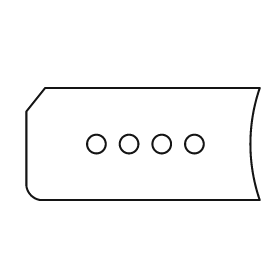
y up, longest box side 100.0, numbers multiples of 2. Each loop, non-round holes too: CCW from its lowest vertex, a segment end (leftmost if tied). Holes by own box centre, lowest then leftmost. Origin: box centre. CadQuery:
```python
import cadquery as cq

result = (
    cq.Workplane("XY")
    .moveTo(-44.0, -24.0)
    .lineTo(50.0, -24.0)
    .threePointArc((46.0, 0.0), (50.0, 24.0))
    .lineTo(-42.0, 24.0)
    .lineTo(-50.0, 14.0)
    .lineTo(-50.0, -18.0)
    .threePointArc((-48.0, -22.0), (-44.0, -24.0))
    .close()
    .moveTo(-20.0, 0.0)
    .circle(4.0)
    .moveTo(-6.0, 0.0)
    .circle(4.0)
    .moveTo(8.0, 0.0)
    .circle(4.0)
    .moveTo(22.0, 0.0)
    .circle(4.0)
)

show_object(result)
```